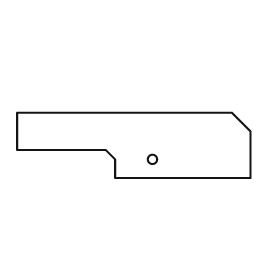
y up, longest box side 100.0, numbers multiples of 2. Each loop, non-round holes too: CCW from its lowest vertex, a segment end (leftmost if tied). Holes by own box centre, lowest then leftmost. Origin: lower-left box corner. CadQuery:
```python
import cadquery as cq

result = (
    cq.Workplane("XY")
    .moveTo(42.0, 0.0)
    .lineTo(100.0, 0.0)
    .lineTo(100.0, 20.0)
    .lineTo(92.0, 28.0)
    .lineTo(0.0, 28.0)
    .lineTo(0.0, 12.0)
    .lineTo(38.0, 12.0)
    .lineTo(42.0, 8.0)
    .close()
    .moveTo(58.0, 8.0)
    .circle(2.0)
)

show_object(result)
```